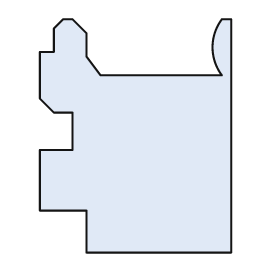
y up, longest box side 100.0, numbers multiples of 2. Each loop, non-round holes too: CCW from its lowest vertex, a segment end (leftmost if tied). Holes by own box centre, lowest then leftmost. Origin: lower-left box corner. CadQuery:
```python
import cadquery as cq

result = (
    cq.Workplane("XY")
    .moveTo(20.0, 0.0)
    .lineTo(82.0, 0.0)
    .lineTo(82.0, 100.0)
    .lineTo(78.0, 100.0)
    .threePointArc((74.0, 88.0), (78.0, 76.0))
    .lineTo(26.0, 76.0)
    .lineTo(20.0, 84.0)
    .lineTo(20.0, 94.0)
    .lineTo(14.0, 100.0)
    .lineTo(10.0, 100.0)
    .lineTo(6.0, 96.0)
    .lineTo(6.0, 86.0)
    .lineTo(0.0, 86.0)
    .lineTo(0.0, 66.0)
    .lineTo(6.0, 60.0)
    .lineTo(14.0, 60.0)
    .lineTo(14.0, 44.0)
    .lineTo(0.0, 44.0)
    .lineTo(0.0, 18.0)
    .lineTo(20.0, 18.0)
    .close()
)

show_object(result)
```